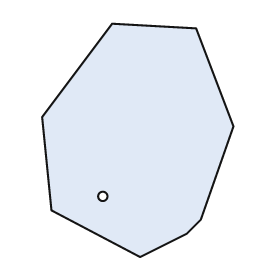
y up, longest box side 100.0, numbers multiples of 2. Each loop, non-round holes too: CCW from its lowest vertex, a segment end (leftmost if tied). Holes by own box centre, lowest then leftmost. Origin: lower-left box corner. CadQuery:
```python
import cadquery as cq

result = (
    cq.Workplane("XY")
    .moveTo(42.0, 0.0)
    .lineTo(62.0, 10.0)
    .lineTo(68.0, 16.0)
    .lineTo(82.0, 56.0)
    .lineTo(66.0, 98.0)
    .lineTo(30.0, 100.0)
    .lineTo(0.0, 60.0)
    .lineTo(4.0, 20.0)
    .close()
    .moveTo(26.0, 26.0)
    .circle(2.0)
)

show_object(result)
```